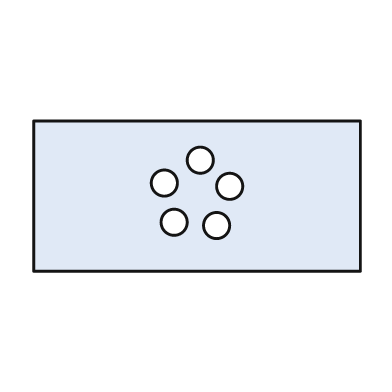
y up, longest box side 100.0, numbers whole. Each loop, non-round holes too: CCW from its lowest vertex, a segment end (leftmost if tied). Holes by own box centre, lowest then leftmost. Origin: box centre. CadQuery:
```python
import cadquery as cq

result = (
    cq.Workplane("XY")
    .moveTo(-50.0, -23.0)
    .lineTo(50.0, -23.0)
    .lineTo(50.0, 23.0)
    .lineTo(-50.0, 23.0)
    .close()
    .moveTo(6.0, -9.0)
    .circle(4.0)
    .moveTo(-7.0, -8.0)
    .circle(4.0)
    .moveTo(10.0, 3.0)
    .circle(4.0)
    .moveTo(-10.0, 4.0)
    .circle(4.0)
    .moveTo(1.0, 11.0)
    .circle(4.0)
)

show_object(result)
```